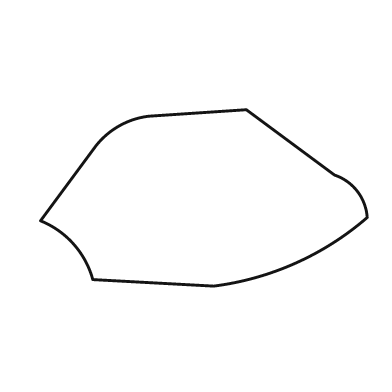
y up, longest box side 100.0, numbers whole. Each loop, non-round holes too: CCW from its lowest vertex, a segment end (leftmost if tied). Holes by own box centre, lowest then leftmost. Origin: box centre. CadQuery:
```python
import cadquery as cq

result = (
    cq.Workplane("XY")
    .moveTo(3.0, -27.0)
    .threePointArc((28.0, -20.0), (50.0, -6.0))
    .threePointArc((47.0, 2.0), (40.0, 7.0))
    .lineTo(13.0, 27.0)
    .lineTo(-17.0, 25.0)
    .threePointArc((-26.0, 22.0), (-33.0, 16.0))
    .lineTo(-50.0, -7.0)
    .threePointArc((-40.0, -14.0), (-34.0, -25.0))
    .close()
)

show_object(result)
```